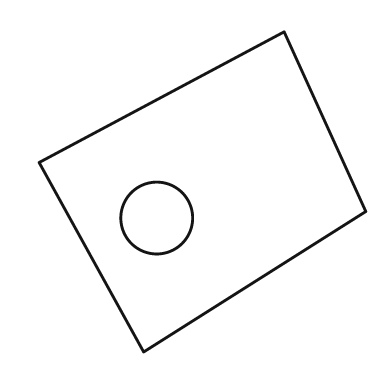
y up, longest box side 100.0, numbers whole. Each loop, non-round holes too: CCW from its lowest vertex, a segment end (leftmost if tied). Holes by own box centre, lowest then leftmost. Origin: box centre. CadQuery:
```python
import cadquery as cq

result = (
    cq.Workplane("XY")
    .moveTo(-18.0, -49.0)
    .lineTo(50.0, -6.0)
    .lineTo(25.0, 49.0)
    .lineTo(-50.0, 9.0)
    .close()
    .moveTo(-14.0, -8.0)
    .circle(11.0)
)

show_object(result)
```